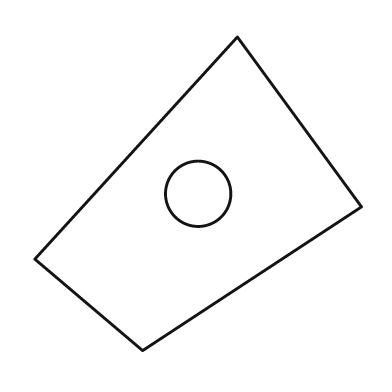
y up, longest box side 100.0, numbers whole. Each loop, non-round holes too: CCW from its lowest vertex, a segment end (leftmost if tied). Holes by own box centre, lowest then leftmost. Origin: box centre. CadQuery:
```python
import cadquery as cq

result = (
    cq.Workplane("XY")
    .moveTo(-17.0, -48.0)
    .lineTo(50.0, -4.0)
    .lineTo(12.0, 48.0)
    .lineTo(-50.0, -20.0)
    .close()
    .moveTo(0.0, 0.0)
    .circle(10.0)
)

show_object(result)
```